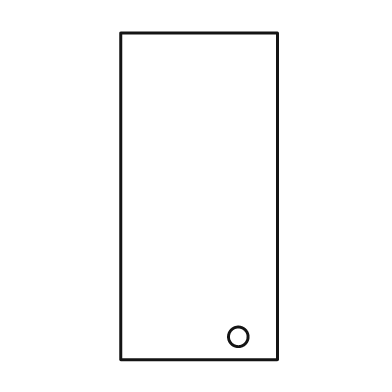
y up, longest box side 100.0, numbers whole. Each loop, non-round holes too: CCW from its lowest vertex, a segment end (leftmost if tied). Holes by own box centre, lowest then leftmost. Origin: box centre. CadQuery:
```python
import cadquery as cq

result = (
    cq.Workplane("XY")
    .moveTo(-24.0, -50.0)
    .lineTo(24.0, -50.0)
    .lineTo(24.0, 50.0)
    .lineTo(-24.0, 50.0)
    .close()
    .moveTo(12.0, -43.0)
    .circle(3.0)
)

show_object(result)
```